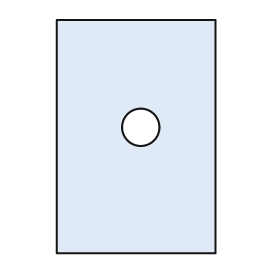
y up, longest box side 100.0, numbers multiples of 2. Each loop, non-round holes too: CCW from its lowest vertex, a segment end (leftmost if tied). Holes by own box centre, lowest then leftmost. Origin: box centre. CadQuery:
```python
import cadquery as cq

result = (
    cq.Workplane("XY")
    .moveTo(-34.0, -50.0)
    .lineTo(34.0, -50.0)
    .lineTo(34.0, 50.0)
    .lineTo(-34.0, 50.0)
    .close()
    .moveTo(2.0, 4.0)
    .circle(8.0)
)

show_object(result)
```